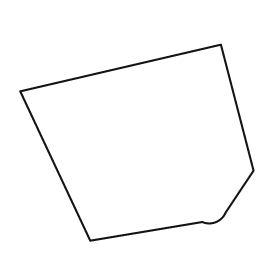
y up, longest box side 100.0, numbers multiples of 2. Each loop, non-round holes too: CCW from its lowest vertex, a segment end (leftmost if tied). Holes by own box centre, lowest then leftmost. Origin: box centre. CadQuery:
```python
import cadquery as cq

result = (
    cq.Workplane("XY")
    .moveTo(-20.0, -42.0)
    .lineTo(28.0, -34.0)
    .threePointArc((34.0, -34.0), (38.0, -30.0))
    .lineTo(50.0, -12.0)
    .lineTo(36.0, 42.0)
    .lineTo(-50.0, 22.0)
    .close()
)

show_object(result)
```